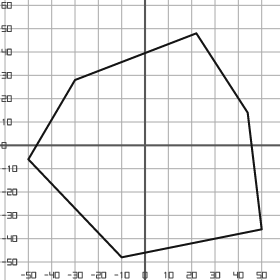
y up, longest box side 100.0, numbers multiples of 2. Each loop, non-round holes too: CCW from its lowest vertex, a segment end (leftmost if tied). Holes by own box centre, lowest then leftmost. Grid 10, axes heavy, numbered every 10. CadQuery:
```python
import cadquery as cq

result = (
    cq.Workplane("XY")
    .moveTo(-10.0, -48.0)
    .lineTo(50.0, -36.0)
    .lineTo(44.0, 14.0)
    .lineTo(22.0, 48.0)
    .lineTo(-30.0, 28.0)
    .lineTo(-50.0, -6.0)
    .close()
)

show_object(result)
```